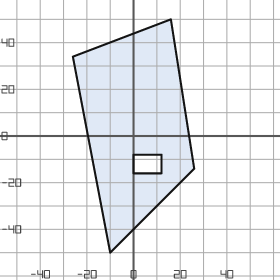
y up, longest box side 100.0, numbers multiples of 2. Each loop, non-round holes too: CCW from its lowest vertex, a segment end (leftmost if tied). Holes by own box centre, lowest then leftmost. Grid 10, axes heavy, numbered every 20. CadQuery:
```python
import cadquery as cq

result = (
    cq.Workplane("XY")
    .moveTo(-10.0, -50.0)
    .lineTo(26.0, -14.0)
    .lineTo(16.0, 50.0)
    .lineTo(-26.0, 34.0)
    .close()
    .moveTo(0.0, -16.0)
    .lineTo(12.0, -16.0)
    .lineTo(12.0, -8.0)
    .lineTo(0.0, -8.0)
    .close()
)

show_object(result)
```